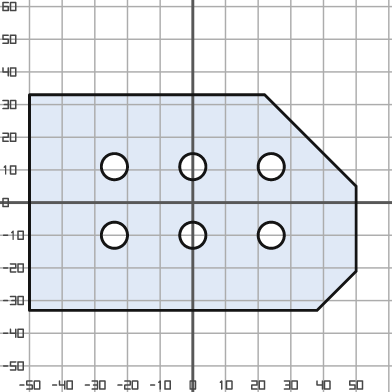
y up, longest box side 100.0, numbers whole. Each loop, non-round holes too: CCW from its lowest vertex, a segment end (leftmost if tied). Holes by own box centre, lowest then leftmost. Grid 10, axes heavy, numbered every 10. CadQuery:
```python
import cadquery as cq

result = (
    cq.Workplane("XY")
    .moveTo(-50.0, -33.0)
    .lineTo(38.0, -33.0)
    .lineTo(50.0, -21.0)
    .lineTo(50.0, 5.0)
    .lineTo(22.0, 33.0)
    .lineTo(-50.0, 33.0)
    .close()
    .moveTo(-24.0, -10.0)
    .circle(4.0)
    .moveTo(0.0, -10.0)
    .circle(4.0)
    .moveTo(24.0, -10.0)
    .circle(4.0)
    .moveTo(-24.0, 11.0)
    .circle(4.0)
    .moveTo(0.0, 11.0)
    .circle(4.0)
    .moveTo(24.0, 11.0)
    .circle(4.0)
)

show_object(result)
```